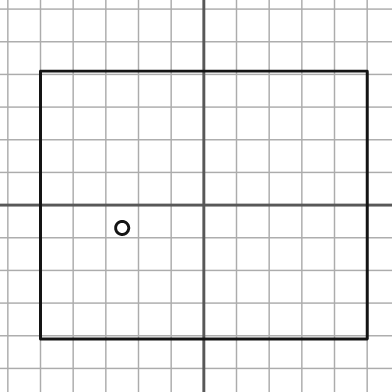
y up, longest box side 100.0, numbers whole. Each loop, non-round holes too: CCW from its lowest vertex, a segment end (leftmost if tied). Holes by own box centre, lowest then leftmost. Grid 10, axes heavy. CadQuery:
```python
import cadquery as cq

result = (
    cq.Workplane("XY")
    .moveTo(-50.0, -41.0)
    .lineTo(50.0, -41.0)
    .lineTo(50.0, 41.0)
    .lineTo(-50.0, 41.0)
    .close()
    .moveTo(-25.0, -7.0)
    .circle(2.0)
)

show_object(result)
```